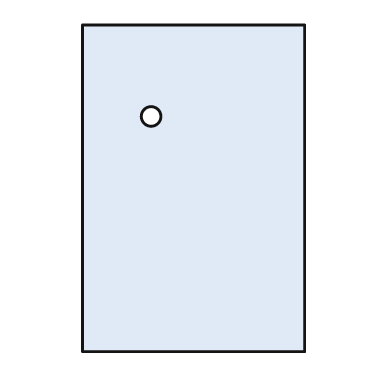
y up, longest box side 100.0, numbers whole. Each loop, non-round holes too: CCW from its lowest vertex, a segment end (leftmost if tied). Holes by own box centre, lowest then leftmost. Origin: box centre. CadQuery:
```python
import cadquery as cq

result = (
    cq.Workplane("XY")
    .moveTo(-34.0, -50.0)
    .lineTo(34.0, -50.0)
    .lineTo(34.0, 50.0)
    .lineTo(-34.0, 50.0)
    .close()
    .moveTo(-13.0, 22.0)
    .circle(3.0)
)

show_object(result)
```